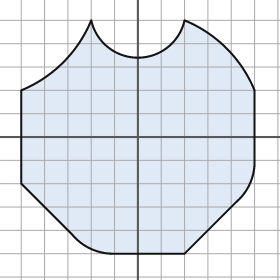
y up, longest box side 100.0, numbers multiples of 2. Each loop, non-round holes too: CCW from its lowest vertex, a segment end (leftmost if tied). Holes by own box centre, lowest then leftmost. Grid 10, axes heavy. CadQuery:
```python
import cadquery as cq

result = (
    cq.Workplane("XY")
    .moveTo(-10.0, -50.0)
    .lineTo(20.0, -50.0)
    .lineTo(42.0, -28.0)
    .threePointArc((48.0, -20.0), (50.0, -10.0))
    .lineTo(50.0, 20.0)
    .threePointArc((38.0, 38.0), (20.0, 50.0))
    .threePointArc((0.0, 34.0), (-20.0, 50.0))
    .threePointArc((-32.0, 32.0), (-50.0, 20.0))
    .lineTo(-50.0, -20.0)
    .lineTo(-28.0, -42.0)
    .threePointArc((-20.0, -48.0), (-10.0, -50.0))
    .close()
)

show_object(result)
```